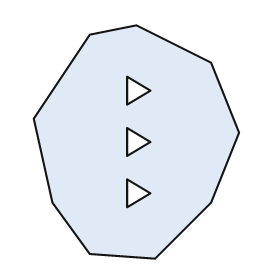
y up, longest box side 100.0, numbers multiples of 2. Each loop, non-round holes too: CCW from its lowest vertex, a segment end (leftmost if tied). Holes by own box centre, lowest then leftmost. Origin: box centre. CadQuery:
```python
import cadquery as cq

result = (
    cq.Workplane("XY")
    .moveTo(8.0, -50.0)
    .lineTo(32.0, -26.0)
    .lineTo(44.0, 4.0)
    .lineTo(32.0, 34.0)
    .lineTo(0.0, 50.0)
    .lineTo(-20.0, 46.0)
    .lineTo(-44.0, 10.0)
    .lineTo(-36.0, -26.0)
    .lineTo(-20.0, -48.0)
    .close()
    .moveTo(-4.0, -28.0)
    .lineTo(6.0, -22.0)
    .lineTo(-4.0, -16.0)
    .close()
    .moveTo(-4.0, -6.0)
    .lineTo(6.0, 0.0)
    .lineTo(-4.0, 6.0)
    .close()
    .moveTo(-4.0, 16.0)
    .lineTo(6.0, 22.0)
    .lineTo(-4.0, 28.0)
    .close()
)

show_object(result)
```